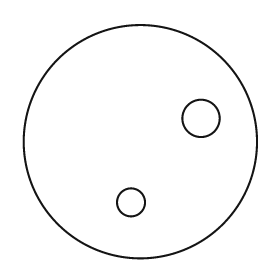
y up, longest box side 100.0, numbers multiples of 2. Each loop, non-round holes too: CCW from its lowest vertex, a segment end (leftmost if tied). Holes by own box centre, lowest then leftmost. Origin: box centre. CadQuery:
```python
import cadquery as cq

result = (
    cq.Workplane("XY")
    .moveTo(0.0, 0.0)
    .circle(50.0)
    .moveTo(-4.0, -26.0)
    .circle(6.0)
    .moveTo(26.0, 10.0)
    .circle(8.0)
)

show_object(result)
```